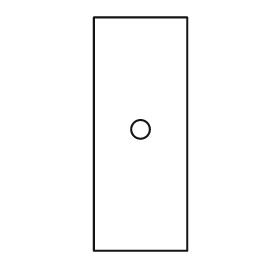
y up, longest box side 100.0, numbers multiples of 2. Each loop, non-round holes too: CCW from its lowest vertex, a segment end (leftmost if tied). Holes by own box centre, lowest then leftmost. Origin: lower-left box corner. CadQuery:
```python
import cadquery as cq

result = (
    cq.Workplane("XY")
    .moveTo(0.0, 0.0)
    .lineTo(40.0, 0.0)
    .lineTo(40.0, 100.0)
    .lineTo(0.0, 100.0)
    .close()
    .moveTo(20.0, 52.0)
    .circle(4.0)
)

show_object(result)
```